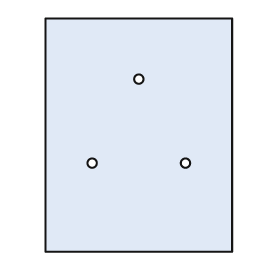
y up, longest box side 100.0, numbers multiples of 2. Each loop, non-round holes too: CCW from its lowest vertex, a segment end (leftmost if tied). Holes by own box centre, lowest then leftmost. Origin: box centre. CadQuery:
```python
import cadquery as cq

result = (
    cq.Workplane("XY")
    .moveTo(-40.0, -50.0)
    .lineTo(40.0, -50.0)
    .lineTo(40.0, 50.0)
    .lineTo(-40.0, 50.0)
    .close()
    .moveTo(-20.0, -12.0)
    .circle(2.0)
    .moveTo(20.0, -12.0)
    .circle(2.0)
    .moveTo(0.0, 24.0)
    .circle(2.0)
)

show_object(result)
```